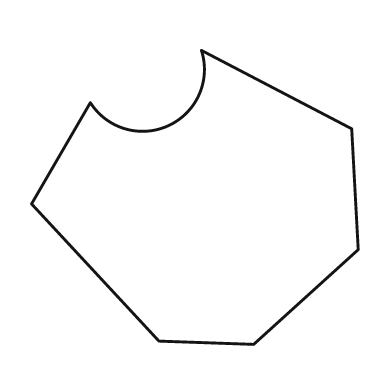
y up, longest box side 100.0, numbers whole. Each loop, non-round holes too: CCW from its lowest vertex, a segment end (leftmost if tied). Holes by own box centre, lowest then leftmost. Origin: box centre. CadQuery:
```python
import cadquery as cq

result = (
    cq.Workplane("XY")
    .moveTo(18.0, -45.0)
    .lineTo(50.0, -16.0)
    .lineTo(48.0, 21.0)
    .lineTo(2.0, 45.0)
    .threePointArc((-8.0, 22.0), (-32.0, 29.0))
    .lineTo(-50.0, -2.0)
    .lineTo(-11.0, -44.0)
    .close()
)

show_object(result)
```